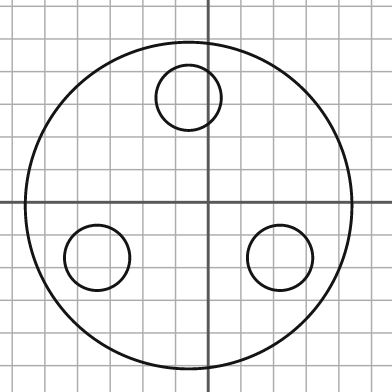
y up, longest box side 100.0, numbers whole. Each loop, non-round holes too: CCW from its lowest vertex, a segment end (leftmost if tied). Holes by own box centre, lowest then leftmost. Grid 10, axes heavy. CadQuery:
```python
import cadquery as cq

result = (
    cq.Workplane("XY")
    .moveTo(-6.0, -1.0)
    .circle(50.0)
    .moveTo(-34.0, -17.0)
    .circle(10.0)
    .moveTo(22.0, -17.0)
    .circle(10.0)
    .moveTo(-6.0, 32.0)
    .circle(10.0)
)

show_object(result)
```